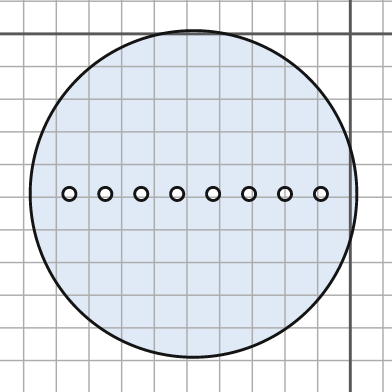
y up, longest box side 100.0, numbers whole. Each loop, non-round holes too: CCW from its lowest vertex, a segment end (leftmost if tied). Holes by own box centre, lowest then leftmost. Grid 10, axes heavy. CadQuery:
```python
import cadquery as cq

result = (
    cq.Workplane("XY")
    .moveTo(-48.0, -49.0)
    .circle(50.0)
    .moveTo(-86.0, -49.0)
    .circle(2.0)
    .moveTo(-75.0, -49.0)
    .circle(2.0)
    .moveTo(-64.0, -49.0)
    .circle(2.0)
    .moveTo(-53.0, -49.0)
    .circle(2.0)
    .moveTo(-42.0, -49.0)
    .circle(2.0)
    .moveTo(-31.0, -49.0)
    .circle(2.0)
    .moveTo(-20.0, -49.0)
    .circle(2.0)
    .moveTo(-9.0, -49.0)
    .circle(2.0)
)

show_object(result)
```